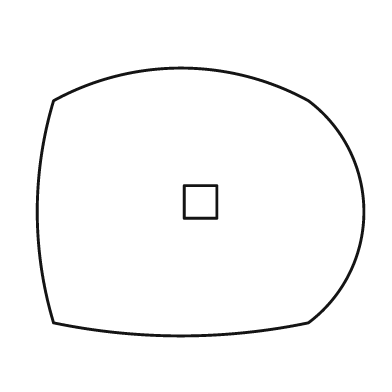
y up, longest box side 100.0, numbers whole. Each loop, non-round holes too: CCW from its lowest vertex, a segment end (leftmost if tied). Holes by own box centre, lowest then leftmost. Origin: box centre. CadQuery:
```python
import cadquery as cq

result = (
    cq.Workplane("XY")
    .moveTo(-45.0, -37.0)
    .threePointArc((-6.0, -41.0), (33.0, -37.0))
    .threePointArc((50.0, -3.0), (33.0, 31.0))
    .threePointArc((-6.0, 41.0), (-45.0, 31.0))
    .threePointArc((-50.0, -3.0), (-45.0, -37.0))
    .close()
    .moveTo(-5.0, -5.0)
    .lineTo(5.0, -5.0)
    .lineTo(5.0, 5.0)
    .lineTo(-5.0, 5.0)
    .close()
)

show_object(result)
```